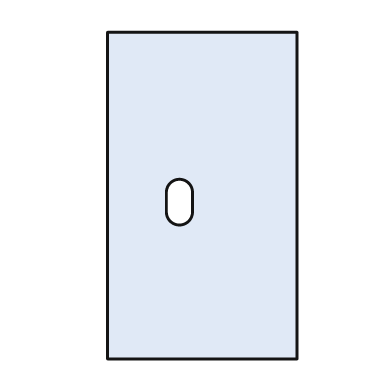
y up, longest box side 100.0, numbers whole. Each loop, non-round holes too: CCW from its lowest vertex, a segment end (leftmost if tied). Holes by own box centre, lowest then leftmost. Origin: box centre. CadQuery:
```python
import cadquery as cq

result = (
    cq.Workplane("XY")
    .moveTo(-29.0, -50.0)
    .lineTo(29.0, -50.0)
    .lineTo(29.0, 50.0)
    .lineTo(-29.0, 50.0)
    .close()
    .moveTo(-11.0, -5.0)
    .threePointArc((-7.0, -9.0), (-3.0, -5.0))
    .lineTo(-3.0, 1.0)
    .threePointArc((-7.0, 5.0), (-11.0, 1.0))
    .close()
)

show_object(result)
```